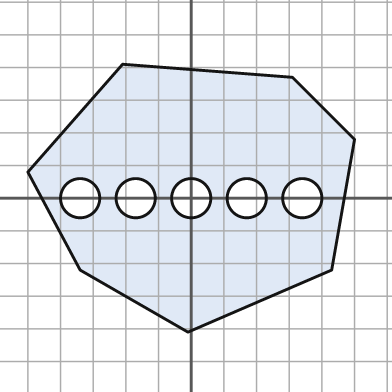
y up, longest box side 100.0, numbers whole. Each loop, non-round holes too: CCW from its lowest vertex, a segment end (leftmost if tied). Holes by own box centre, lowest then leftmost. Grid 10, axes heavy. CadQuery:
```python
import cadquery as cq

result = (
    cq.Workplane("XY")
    .moveTo(-1.0, -41.0)
    .lineTo(43.0, -22.0)
    .lineTo(50.0, 18.0)
    .lineTo(31.0, 37.0)
    .lineTo(-21.0, 41.0)
    .lineTo(-50.0, 8.0)
    .lineTo(-34.0, -22.0)
    .close()
    .moveTo(-34.0, 0.0)
    .circle(6.0)
    .moveTo(-17.0, 0.0)
    .circle(6.0)
    .moveTo(0.0, 0.0)
    .circle(6.0)
    .moveTo(17.0, 0.0)
    .circle(6.0)
    .moveTo(34.0, 0.0)
    .circle(6.0)
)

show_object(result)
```